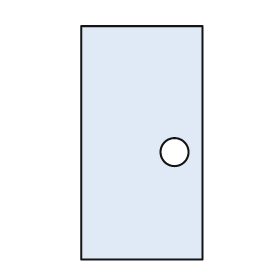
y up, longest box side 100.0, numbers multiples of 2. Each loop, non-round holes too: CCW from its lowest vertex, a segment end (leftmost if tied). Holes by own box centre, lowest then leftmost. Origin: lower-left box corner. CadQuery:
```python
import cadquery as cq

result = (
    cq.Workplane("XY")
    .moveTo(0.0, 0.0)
    .lineTo(52.0, 0.0)
    .lineTo(52.0, 100.0)
    .lineTo(0.0, 100.0)
    .close()
    .moveTo(40.0, 46.0)
    .circle(6.0)
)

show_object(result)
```